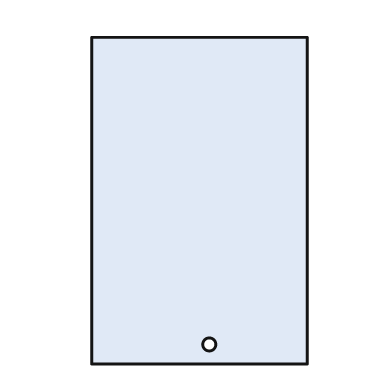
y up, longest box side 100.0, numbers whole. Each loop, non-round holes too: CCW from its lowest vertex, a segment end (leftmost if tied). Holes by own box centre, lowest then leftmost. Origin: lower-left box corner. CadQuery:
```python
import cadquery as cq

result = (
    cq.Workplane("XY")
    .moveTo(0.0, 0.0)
    .lineTo(66.0, 0.0)
    .lineTo(66.0, 100.0)
    .lineTo(0.0, 100.0)
    .close()
    .moveTo(36.0, 6.0)
    .circle(2.0)
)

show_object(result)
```